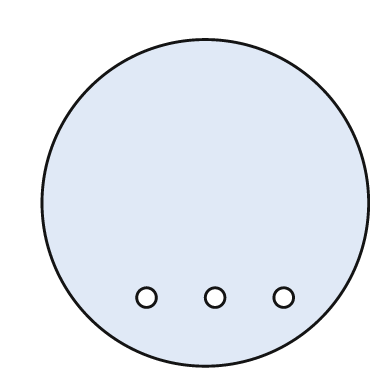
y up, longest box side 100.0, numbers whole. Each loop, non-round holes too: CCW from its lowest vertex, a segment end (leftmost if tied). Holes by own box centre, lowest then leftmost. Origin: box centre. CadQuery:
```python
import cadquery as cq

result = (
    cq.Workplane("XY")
    .moveTo(0.0, 0.0)
    .circle(50.0)
    .moveTo(-18.0, -29.0)
    .circle(3.0)
    .moveTo(3.0, -29.0)
    .circle(3.0)
    .moveTo(24.0, -29.0)
    .circle(3.0)
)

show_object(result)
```